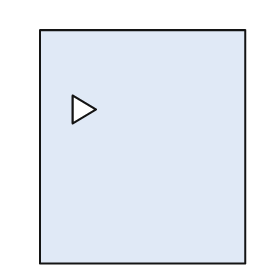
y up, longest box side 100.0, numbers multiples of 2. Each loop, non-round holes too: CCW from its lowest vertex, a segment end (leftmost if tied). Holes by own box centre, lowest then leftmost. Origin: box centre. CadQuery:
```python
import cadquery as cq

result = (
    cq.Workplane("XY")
    .moveTo(-44.0, -50.0)
    .lineTo(44.0, -50.0)
    .lineTo(44.0, 50.0)
    .lineTo(-44.0, 50.0)
    .close()
    .moveTo(-30.0, 10.0)
    .lineTo(-20.0, 16.0)
    .lineTo(-30.0, 22.0)
    .close()
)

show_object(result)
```